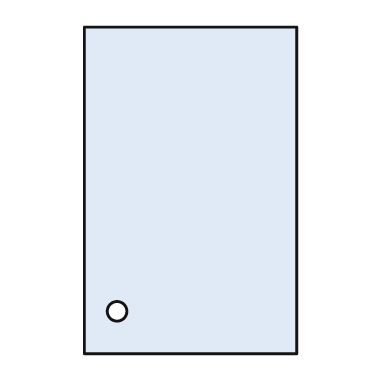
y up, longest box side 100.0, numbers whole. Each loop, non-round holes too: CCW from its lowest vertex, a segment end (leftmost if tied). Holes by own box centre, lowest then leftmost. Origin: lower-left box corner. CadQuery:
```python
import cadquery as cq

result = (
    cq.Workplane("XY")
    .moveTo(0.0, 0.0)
    .lineTo(65.0, 0.0)
    .lineTo(65.0, 100.0)
    .lineTo(0.0, 100.0)
    .close()
    .moveTo(10.0, 13.0)
    .circle(3.0)
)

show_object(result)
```